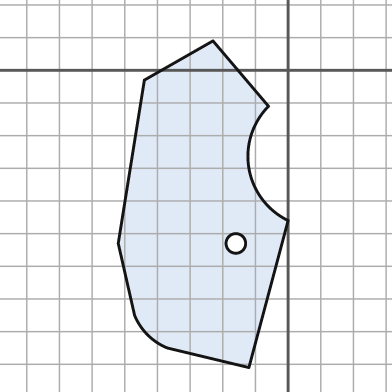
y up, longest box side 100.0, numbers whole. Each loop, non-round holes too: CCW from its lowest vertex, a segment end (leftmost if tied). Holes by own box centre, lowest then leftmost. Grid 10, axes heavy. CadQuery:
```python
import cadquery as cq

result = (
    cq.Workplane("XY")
    .moveTo(-12.0, -91.0)
    .lineTo(0.0, -46.0)
    .threePointArc((-12.0, -30.0), (-6.0, -11.0))
    .lineTo(-23.0, 9.0)
    .lineTo(-44.0, -3.0)
    .lineTo(-52.0, -53.0)
    .lineTo(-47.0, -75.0)
    .threePointArc((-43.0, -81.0), (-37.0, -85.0))
    .close()
    .moveTo(-16.0, -53.0)
    .circle(3.0)
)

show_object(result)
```